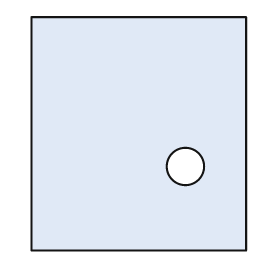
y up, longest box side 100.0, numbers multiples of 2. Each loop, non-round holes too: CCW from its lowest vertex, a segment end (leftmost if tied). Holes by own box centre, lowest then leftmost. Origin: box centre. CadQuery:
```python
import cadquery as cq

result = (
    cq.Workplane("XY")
    .moveTo(-46.0, -50.0)
    .lineTo(46.0, -50.0)
    .lineTo(46.0, 50.0)
    .lineTo(-46.0, 50.0)
    .close()
    .moveTo(20.0, -14.0)
    .circle(8.0)
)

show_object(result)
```